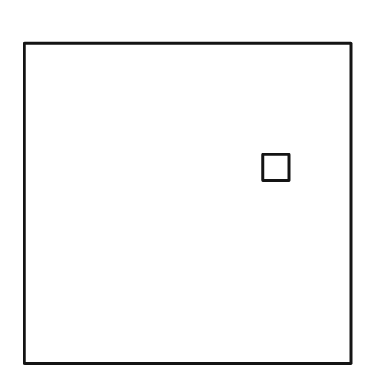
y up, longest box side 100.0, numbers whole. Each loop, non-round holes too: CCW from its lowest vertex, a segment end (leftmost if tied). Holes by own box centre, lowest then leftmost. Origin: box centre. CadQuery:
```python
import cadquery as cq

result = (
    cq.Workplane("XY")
    .moveTo(-50.0, -49.0)
    .lineTo(50.0, -49.0)
    .lineTo(50.0, 49.0)
    .lineTo(-50.0, 49.0)
    .close()
    .moveTo(23.0, 7.0)
    .lineTo(31.0, 7.0)
    .lineTo(31.0, 15.0)
    .lineTo(23.0, 15.0)
    .close()
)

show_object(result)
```